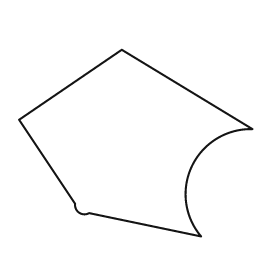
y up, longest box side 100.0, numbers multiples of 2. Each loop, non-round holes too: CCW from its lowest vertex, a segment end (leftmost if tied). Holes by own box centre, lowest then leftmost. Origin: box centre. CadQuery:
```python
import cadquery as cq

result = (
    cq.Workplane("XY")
    .moveTo(28.0, -40.0)
    .threePointArc((24.0, -10.0), (50.0, 6.0))
    .lineTo(-6.0, 40.0)
    .lineTo(-50.0, 10.0)
    .lineTo(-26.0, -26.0)
    .threePointArc((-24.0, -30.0), (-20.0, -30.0))
    .close()
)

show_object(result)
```